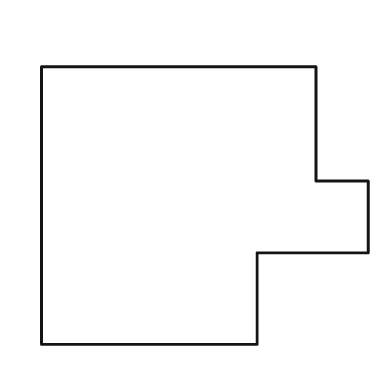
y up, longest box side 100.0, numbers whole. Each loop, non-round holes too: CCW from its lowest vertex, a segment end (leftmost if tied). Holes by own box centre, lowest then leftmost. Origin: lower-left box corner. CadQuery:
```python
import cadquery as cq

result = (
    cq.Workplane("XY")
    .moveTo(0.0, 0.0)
    .lineTo(66.0, 0.0)
    .lineTo(66.0, 28.0)
    .lineTo(100.0, 28.0)
    .lineTo(100.0, 50.0)
    .lineTo(84.0, 50.0)
    .lineTo(84.0, 85.0)
    .lineTo(0.0, 85.0)
    .close()
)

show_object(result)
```